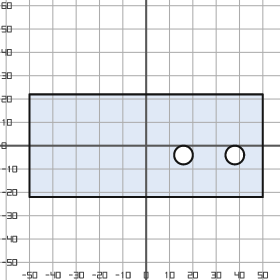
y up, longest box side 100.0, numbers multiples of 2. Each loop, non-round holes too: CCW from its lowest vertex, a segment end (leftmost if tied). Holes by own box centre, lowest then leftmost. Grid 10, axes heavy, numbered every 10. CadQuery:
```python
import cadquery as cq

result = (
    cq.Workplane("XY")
    .moveTo(-50.0, -22.0)
    .lineTo(50.0, -22.0)
    .lineTo(50.0, 22.0)
    .lineTo(-50.0, 22.0)
    .close()
    .moveTo(16.0, -4.0)
    .circle(4.0)
    .moveTo(38.0, -4.0)
    .circle(4.0)
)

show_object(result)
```